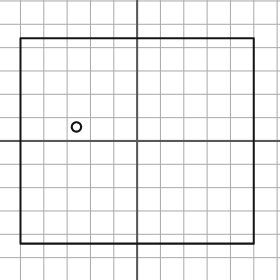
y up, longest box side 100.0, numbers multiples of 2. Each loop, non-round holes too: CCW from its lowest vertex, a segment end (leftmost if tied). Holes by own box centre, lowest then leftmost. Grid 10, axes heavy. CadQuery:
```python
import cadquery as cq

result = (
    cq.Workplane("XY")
    .moveTo(-50.0, -44.0)
    .lineTo(50.0, -44.0)
    .lineTo(50.0, 44.0)
    .lineTo(-50.0, 44.0)
    .close()
    .moveTo(-26.0, 6.0)
    .circle(2.0)
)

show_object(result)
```